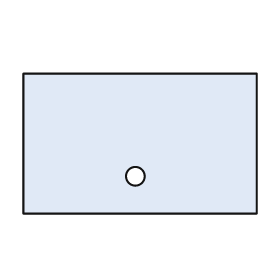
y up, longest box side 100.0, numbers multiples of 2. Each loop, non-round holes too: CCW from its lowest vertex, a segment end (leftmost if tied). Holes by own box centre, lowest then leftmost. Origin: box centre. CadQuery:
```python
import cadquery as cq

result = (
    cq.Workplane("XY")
    .moveTo(-50.0, -30.0)
    .lineTo(50.0, -30.0)
    .lineTo(50.0, 30.0)
    .lineTo(-50.0, 30.0)
    .close()
    .moveTo(-2.0, -14.0)
    .circle(4.0)
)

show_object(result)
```